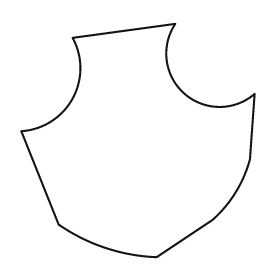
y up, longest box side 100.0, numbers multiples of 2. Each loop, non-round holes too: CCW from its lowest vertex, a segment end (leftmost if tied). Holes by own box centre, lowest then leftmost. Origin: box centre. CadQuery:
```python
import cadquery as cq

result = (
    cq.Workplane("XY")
    .moveTo(8.0, -50.0)
    .lineTo(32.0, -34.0)
    .threePointArc((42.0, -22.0), (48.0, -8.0))
    .lineTo(50.0, 20.0)
    .threePointArc((20.0, 20.0), (16.0, 50.0))
    .lineTo(-28.0, 44.0)
    .threePointArc((-28.0, 18.0), (-50.0, 4.0))
    .lineTo(-34.0, -36.0)
    .threePointArc((-14.0, -46.0), (8.0, -50.0))
    .close()
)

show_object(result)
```